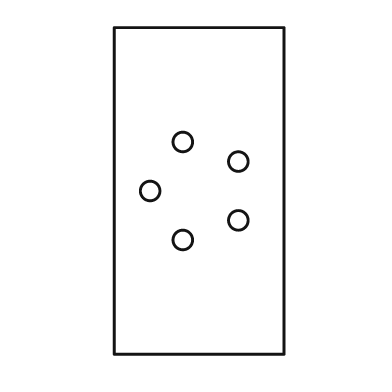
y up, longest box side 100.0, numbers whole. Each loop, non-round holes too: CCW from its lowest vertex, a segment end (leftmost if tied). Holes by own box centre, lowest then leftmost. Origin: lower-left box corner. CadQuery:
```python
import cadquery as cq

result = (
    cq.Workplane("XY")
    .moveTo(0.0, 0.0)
    .lineTo(52.0, 0.0)
    .lineTo(52.0, 100.0)
    .lineTo(0.0, 100.0)
    .close()
    .moveTo(21.0, 35.0)
    .circle(3.0)
    .moveTo(38.0, 41.0)
    .circle(3.0)
    .moveTo(11.0, 50.0)
    .circle(3.0)
    .moveTo(38.0, 59.0)
    .circle(3.0)
    .moveTo(21.0, 65.0)
    .circle(3.0)
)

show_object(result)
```